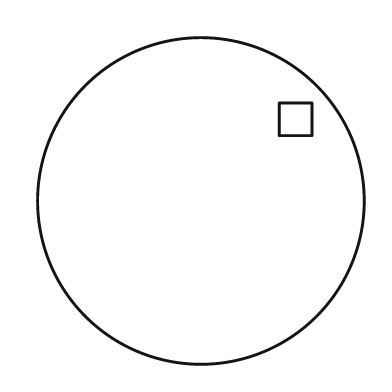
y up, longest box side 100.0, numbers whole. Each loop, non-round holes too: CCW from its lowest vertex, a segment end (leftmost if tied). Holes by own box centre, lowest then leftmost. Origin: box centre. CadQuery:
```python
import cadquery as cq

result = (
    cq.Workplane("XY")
    .moveTo(0.0, 0.0)
    .circle(50.0)
    .moveTo(24.0, 20.0)
    .lineTo(34.0, 20.0)
    .lineTo(34.0, 30.0)
    .lineTo(24.0, 30.0)
    .close()
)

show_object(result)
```